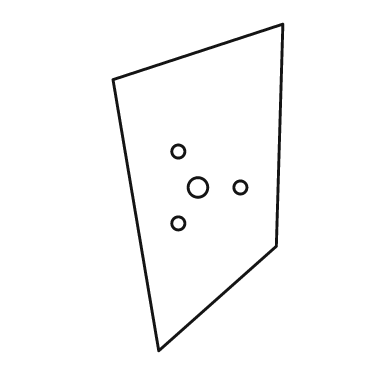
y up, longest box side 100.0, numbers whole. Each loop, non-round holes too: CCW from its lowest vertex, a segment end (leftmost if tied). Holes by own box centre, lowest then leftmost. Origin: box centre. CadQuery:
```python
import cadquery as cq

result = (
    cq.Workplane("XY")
    .moveTo(-12.0, -50.0)
    .lineTo(24.0, -18.0)
    .lineTo(26.0, 50.0)
    .lineTo(-26.0, 33.0)
    .close()
    .moveTo(-6.0, -11.0)
    .circle(2.0)
    .moveTo(0.0, 0.0)
    .circle(3.0)
    .moveTo(13.0, 0.0)
    .circle(2.0)
    .moveTo(-6.0, 11.0)
    .circle(2.0)
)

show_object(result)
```